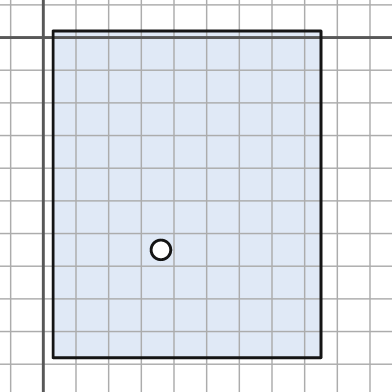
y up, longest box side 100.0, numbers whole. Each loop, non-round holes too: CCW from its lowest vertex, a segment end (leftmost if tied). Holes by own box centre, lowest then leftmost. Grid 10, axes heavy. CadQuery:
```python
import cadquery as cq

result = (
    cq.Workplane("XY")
    .moveTo(3.0, -98.0)
    .lineTo(85.0, -98.0)
    .lineTo(85.0, 2.0)
    .lineTo(3.0, 2.0)
    .close()
    .moveTo(36.0, -65.0)
    .circle(3.0)
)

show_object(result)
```